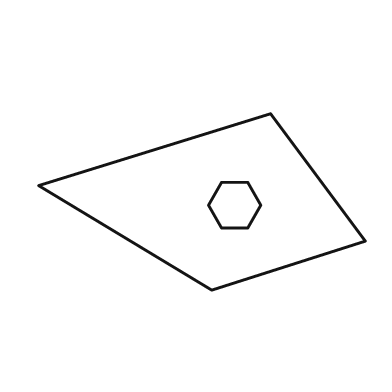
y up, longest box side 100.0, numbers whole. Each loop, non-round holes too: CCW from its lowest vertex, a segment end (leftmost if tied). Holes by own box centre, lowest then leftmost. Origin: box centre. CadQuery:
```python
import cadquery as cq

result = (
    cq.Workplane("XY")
    .moveTo(3.0, -27.0)
    .lineTo(50.0, -12.0)
    .lineTo(21.0, 27.0)
    .lineTo(-50.0, 5.0)
    .close()
    .moveTo(6.0, -8.0)
    .lineTo(14.0, -8.0)
    .lineTo(18.0, -1.0)
    .lineTo(14.0, 6.0)
    .lineTo(6.0, 6.0)
    .lineTo(2.0, -1.0)
    .close()
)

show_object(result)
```